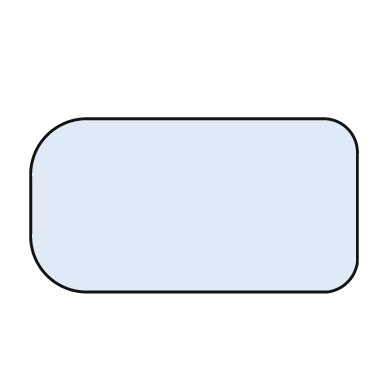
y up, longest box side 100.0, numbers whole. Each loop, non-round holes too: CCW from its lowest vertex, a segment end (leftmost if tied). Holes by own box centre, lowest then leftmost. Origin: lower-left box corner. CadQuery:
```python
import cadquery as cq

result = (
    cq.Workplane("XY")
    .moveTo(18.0, 0.0)
    .lineTo(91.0, 0.0)
    .threePointArc((97.0, 3.0), (100.0, 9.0))
    .lineTo(100.0, 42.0)
    .threePointArc((97.0, 50.0), (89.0, 53.0))
    .lineTo(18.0, 53.0)
    .threePointArc((5.0, 48.0), (0.0, 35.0))
    .lineTo(0.0, 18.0)
    .threePointArc((5.0, 5.0), (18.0, 0.0))
    .close()
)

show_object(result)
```